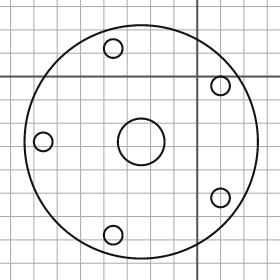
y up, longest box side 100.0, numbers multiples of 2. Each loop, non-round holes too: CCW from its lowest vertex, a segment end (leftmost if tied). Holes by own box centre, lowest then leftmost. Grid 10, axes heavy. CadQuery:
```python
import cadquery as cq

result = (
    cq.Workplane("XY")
    .moveTo(-24.0, -28.0)
    .circle(50.0)
    .moveTo(-36.0, -68.0)
    .circle(4.0)
    .moveTo(10.0, -52.0)
    .circle(4.0)
    .moveTo(-66.0, -28.0)
    .circle(4.0)
    .moveTo(-24.0, -28.0)
    .circle(10.0)
    .moveTo(10.0, -4.0)
    .circle(4.0)
    .moveTo(-36.0, 12.0)
    .circle(4.0)
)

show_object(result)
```